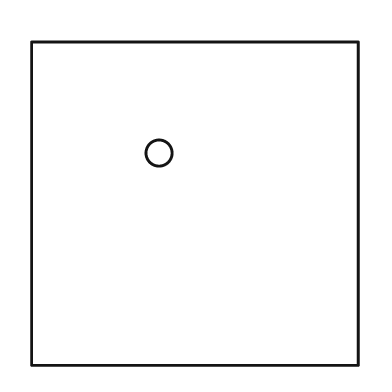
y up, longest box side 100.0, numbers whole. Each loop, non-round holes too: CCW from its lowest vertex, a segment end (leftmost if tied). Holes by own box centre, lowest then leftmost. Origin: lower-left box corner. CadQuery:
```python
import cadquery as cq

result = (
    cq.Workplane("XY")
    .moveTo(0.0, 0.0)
    .lineTo(100.0, 0.0)
    .lineTo(100.0, 99.0)
    .lineTo(0.0, 99.0)
    .close()
    .moveTo(39.0, 65.0)
    .circle(4.0)
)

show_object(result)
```